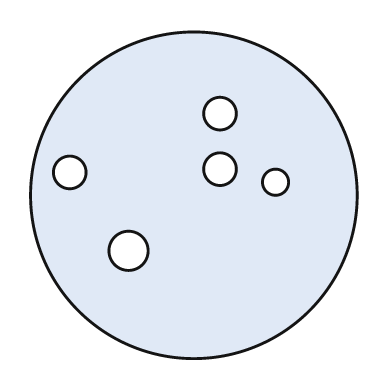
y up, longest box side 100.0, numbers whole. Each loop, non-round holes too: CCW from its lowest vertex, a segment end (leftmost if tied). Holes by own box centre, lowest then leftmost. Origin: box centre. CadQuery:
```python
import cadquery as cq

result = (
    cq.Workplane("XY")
    .moveTo(0.0, 0.0)
    .circle(50.0)
    .moveTo(-20.0, -17.0)
    .circle(6.0)
    .moveTo(25.0, 4.0)
    .circle(4.0)
    .moveTo(-38.0, 7.0)
    .circle(5.0)
    .moveTo(8.0, 8.0)
    .circle(5.0)
    .moveTo(8.0, 25.0)
    .circle(5.0)
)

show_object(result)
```